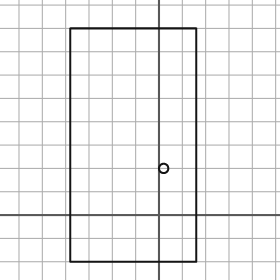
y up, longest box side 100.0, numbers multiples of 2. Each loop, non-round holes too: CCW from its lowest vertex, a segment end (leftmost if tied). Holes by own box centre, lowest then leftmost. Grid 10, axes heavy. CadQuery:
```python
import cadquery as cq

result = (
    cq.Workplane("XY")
    .moveTo(-38.0, -20.0)
    .lineTo(16.0, -20.0)
    .lineTo(16.0, 80.0)
    .lineTo(-38.0, 80.0)
    .close()
    .moveTo(2.0, 20.0)
    .circle(2.0)
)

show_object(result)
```